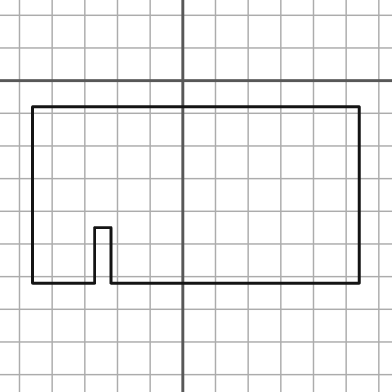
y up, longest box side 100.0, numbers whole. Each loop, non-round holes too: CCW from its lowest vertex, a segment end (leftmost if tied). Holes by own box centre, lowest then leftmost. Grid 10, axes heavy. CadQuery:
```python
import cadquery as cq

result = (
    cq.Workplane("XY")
    .moveTo(-46.0, -62.0)
    .lineTo(-27.0, -62.0)
    .lineTo(-27.0, -45.0)
    .lineTo(-22.0, -45.0)
    .lineTo(-22.0, -62.0)
    .lineTo(54.0, -62.0)
    .lineTo(54.0, -8.0)
    .lineTo(-46.0, -8.0)
    .close()
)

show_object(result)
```